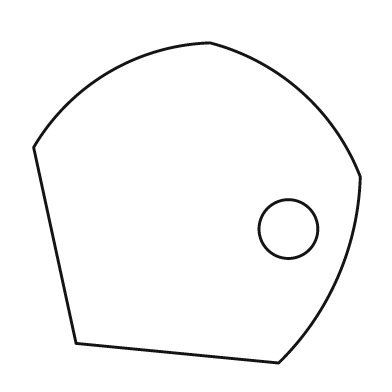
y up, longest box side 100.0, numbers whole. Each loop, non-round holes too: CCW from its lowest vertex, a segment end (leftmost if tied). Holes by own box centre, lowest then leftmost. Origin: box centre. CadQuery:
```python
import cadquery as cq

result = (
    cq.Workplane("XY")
    .moveTo(25.0, -49.0)
    .threePointArc((43.0, -23.0), (50.0, 8.0))
    .threePointArc((32.0, 34.0), (4.0, 49.0))
    .threePointArc((-27.0, 40.0), (-50.0, 17.0))
    .lineTo(-37.0, -43.0)
    .close()
    .moveTo(28.0, -8.0)
    .circle(9.0)
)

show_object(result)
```